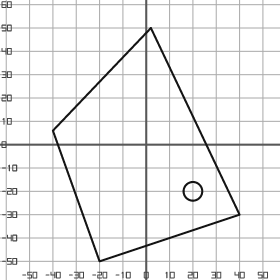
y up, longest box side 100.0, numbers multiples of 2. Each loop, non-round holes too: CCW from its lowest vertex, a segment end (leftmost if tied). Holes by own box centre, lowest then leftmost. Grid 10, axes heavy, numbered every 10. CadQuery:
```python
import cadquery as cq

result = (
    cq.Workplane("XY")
    .moveTo(-20.0, -50.0)
    .lineTo(40.0, -30.0)
    .lineTo(2.0, 50.0)
    .lineTo(-40.0, 6.0)
    .close()
    .moveTo(20.0, -20.0)
    .circle(4.0)
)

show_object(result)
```